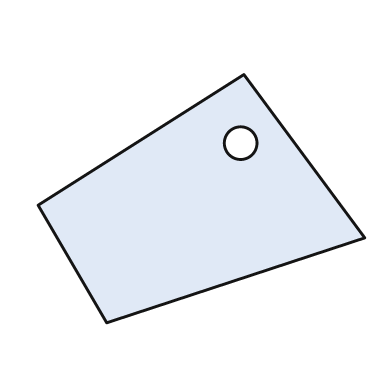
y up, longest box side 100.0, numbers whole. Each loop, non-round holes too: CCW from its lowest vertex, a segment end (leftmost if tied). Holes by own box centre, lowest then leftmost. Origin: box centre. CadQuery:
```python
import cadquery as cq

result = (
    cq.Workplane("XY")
    .moveTo(-29.0, -38.0)
    .lineTo(50.0, -12.0)
    .lineTo(13.0, 38.0)
    .lineTo(-50.0, -2.0)
    .close()
    .moveTo(12.0, 17.0)
    .circle(5.0)
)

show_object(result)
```